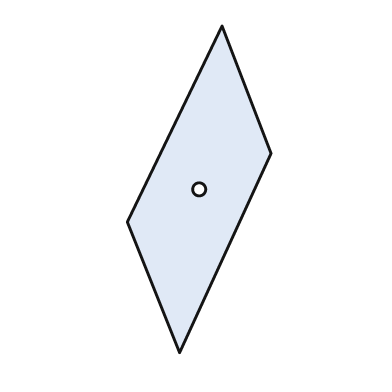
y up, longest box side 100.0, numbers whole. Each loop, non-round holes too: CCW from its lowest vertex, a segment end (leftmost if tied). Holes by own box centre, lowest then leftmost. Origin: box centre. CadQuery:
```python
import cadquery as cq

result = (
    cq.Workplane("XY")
    .moveTo(-6.0, -50.0)
    .lineTo(22.0, 11.0)
    .lineTo(7.0, 50.0)
    .lineTo(-22.0, -10.0)
    .close()
    .moveTo(0.0, 0.0)
    .circle(2.0)
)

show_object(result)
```